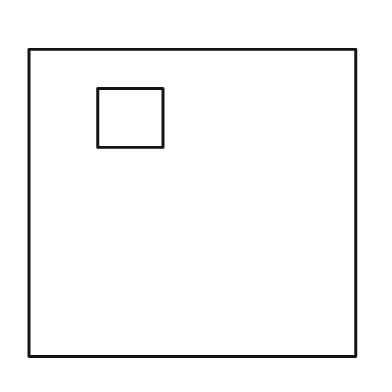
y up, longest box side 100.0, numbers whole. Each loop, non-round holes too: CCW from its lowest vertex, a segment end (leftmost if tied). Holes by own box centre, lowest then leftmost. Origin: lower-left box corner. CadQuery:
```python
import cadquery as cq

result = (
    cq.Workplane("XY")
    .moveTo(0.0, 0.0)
    .lineTo(100.0, 0.0)
    .lineTo(100.0, 94.0)
    .lineTo(0.0, 94.0)
    .close()
    .moveTo(21.0, 64.0)
    .lineTo(41.0, 64.0)
    .lineTo(41.0, 82.0)
    .lineTo(21.0, 82.0)
    .close()
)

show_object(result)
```